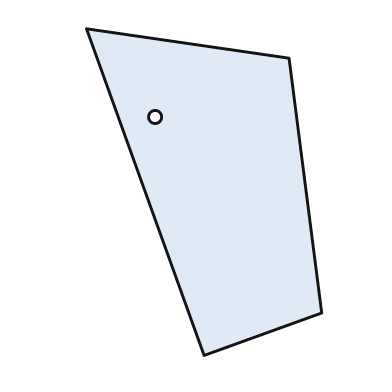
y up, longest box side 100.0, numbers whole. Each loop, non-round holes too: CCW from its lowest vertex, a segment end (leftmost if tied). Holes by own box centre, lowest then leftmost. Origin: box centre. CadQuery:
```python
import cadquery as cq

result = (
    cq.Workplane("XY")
    .moveTo(0.0, -50.0)
    .lineTo(36.0, -37.0)
    .lineTo(26.0, 41.0)
    .lineTo(-36.0, 50.0)
    .close()
    .moveTo(-15.0, 23.0)
    .circle(2.0)
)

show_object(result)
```